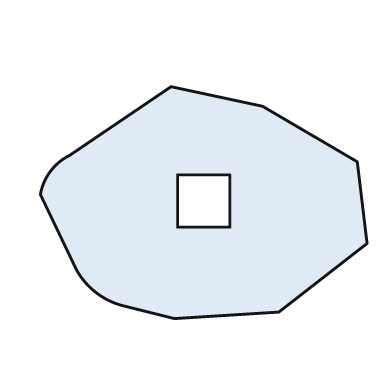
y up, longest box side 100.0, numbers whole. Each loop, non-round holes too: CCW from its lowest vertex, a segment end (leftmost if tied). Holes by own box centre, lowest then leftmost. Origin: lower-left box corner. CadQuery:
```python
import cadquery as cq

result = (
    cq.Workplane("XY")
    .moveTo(41.0, 0.0)
    .lineTo(73.0, 2.0)
    .lineTo(100.0, 23.0)
    .lineTo(97.0, 48.0)
    .lineTo(68.0, 65.0)
    .lineTo(40.0, 71.0)
    .lineTo(9.0, 50.0)
    .threePointArc((3.0, 45.0), (0.0, 38.0))
    .lineTo(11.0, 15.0)
    .threePointArc((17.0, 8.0), (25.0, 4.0))
    .close()
    .moveTo(42.0, 28.0)
    .lineTo(58.0, 28.0)
    .lineTo(58.0, 44.0)
    .lineTo(42.0, 44.0)
    .close()
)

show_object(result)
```